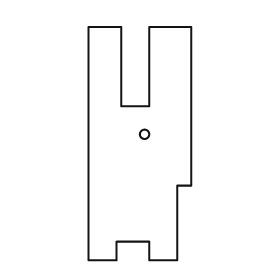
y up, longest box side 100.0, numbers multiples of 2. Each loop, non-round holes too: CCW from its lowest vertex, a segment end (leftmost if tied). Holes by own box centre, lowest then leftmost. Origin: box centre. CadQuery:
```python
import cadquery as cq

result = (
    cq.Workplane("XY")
    .moveTo(-22.0, -50.0)
    .lineTo(-10.0, -50.0)
    .lineTo(-10.0, -42.0)
    .lineTo(4.0, -42.0)
    .lineTo(4.0, -50.0)
    .lineTo(16.0, -50.0)
    .lineTo(16.0, -18.0)
    .lineTo(22.0, -18.0)
    .lineTo(22.0, 50.0)
    .lineTo(4.0, 50.0)
    .lineTo(4.0, 16.0)
    .lineTo(-8.0, 16.0)
    .lineTo(-8.0, 50.0)
    .lineTo(-22.0, 50.0)
    .close()
    .moveTo(2.0, 4.0)
    .circle(2.0)
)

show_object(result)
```